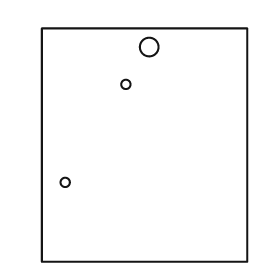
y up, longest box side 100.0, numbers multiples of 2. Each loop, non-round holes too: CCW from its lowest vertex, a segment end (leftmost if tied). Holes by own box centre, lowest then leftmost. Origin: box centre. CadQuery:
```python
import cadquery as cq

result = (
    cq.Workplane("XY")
    .moveTo(-44.0, -50.0)
    .lineTo(44.0, -50.0)
    .lineTo(44.0, 50.0)
    .lineTo(-44.0, 50.0)
    .close()
    .moveTo(-34.0, -16.0)
    .circle(2.0)
    .moveTo(-8.0, 26.0)
    .circle(2.0)
    .moveTo(2.0, 42.0)
    .circle(4.0)
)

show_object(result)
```